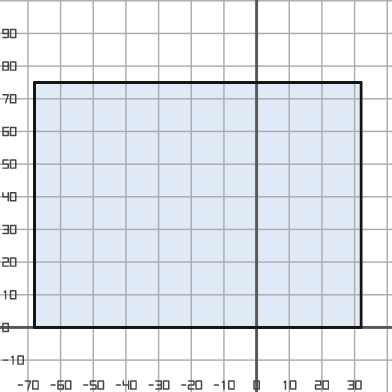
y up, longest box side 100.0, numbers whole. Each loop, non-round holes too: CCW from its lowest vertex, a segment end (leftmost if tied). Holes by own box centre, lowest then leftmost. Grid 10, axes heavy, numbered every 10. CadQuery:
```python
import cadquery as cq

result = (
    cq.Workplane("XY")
    .moveTo(-68.0, 0.0)
    .lineTo(32.0, 0.0)
    .lineTo(32.0, 75.0)
    .lineTo(-68.0, 75.0)
    .close()
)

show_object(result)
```